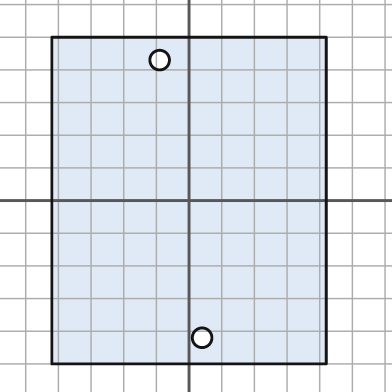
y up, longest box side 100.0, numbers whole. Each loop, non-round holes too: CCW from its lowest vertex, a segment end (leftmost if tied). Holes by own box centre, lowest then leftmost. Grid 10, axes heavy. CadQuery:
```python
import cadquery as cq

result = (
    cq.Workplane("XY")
    .moveTo(-42.0, -50.0)
    .lineTo(42.0, -50.0)
    .lineTo(42.0, 50.0)
    .lineTo(-42.0, 50.0)
    .close()
    .moveTo(4.0, -42.0)
    .circle(3.0)
    .moveTo(-9.0, 43.0)
    .circle(3.0)
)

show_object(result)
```